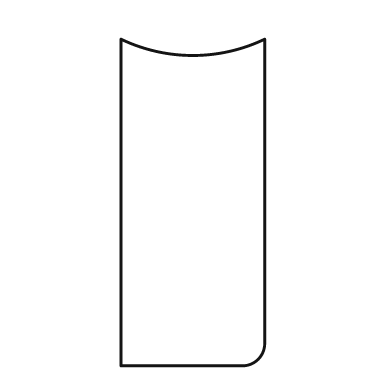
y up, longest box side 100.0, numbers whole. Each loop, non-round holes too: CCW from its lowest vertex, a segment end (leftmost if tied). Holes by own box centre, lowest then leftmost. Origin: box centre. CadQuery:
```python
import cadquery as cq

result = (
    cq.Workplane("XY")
    .moveTo(-22.0, -50.0)
    .lineTo(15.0, -50.0)
    .threePointArc((20.0, -48.0), (22.0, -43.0))
    .lineTo(22.0, 50.0)
    .threePointArc((0.0, 45.0), (-22.0, 50.0))
    .close()
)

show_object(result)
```